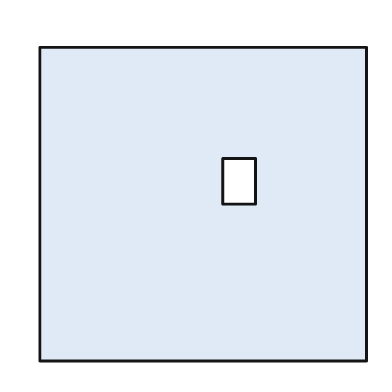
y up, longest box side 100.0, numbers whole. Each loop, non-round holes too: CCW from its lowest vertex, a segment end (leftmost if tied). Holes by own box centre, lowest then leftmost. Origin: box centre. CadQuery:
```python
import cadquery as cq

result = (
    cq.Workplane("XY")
    .moveTo(-50.0, -48.0)
    .lineTo(50.0, -48.0)
    .lineTo(50.0, 48.0)
    .lineTo(-50.0, 48.0)
    .close()
    .moveTo(6.0, 0.0)
    .lineTo(16.0, 0.0)
    .lineTo(16.0, 14.0)
    .lineTo(6.0, 14.0)
    .close()
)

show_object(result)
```